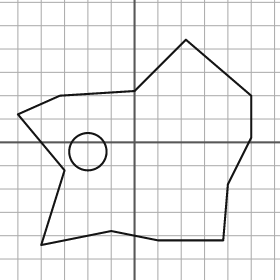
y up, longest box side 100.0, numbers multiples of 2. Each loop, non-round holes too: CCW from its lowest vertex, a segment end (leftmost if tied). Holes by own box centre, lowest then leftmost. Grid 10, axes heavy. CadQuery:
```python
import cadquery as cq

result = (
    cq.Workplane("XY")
    .moveTo(-40.0, -44.0)
    .lineTo(-10.0, -38.0)
    .lineTo(10.0, -42.0)
    .lineTo(38.0, -42.0)
    .lineTo(40.0, -18.0)
    .lineTo(50.0, 2.0)
    .lineTo(50.0, 20.0)
    .lineTo(22.0, 44.0)
    .lineTo(0.0, 22.0)
    .lineTo(-32.0, 20.0)
    .lineTo(-50.0, 12.0)
    .lineTo(-30.0, -12.0)
    .close()
    .moveTo(-20.0, -4.0)
    .circle(8.0)
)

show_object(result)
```